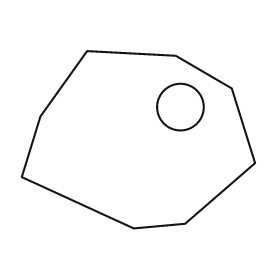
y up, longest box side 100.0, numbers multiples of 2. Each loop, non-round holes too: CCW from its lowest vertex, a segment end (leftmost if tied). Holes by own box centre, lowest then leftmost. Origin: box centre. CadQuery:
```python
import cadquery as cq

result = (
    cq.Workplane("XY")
    .moveTo(-2.0, -38.0)
    .lineTo(20.0, -36.0)
    .lineTo(50.0, -10.0)
    .lineTo(40.0, 22.0)
    .lineTo(16.0, 36.0)
    .lineTo(-22.0, 38.0)
    .lineTo(-42.0, 10.0)
    .lineTo(-50.0, -16.0)
    .close()
    .moveTo(18.0, 14.0)
    .circle(10.0)
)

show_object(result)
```